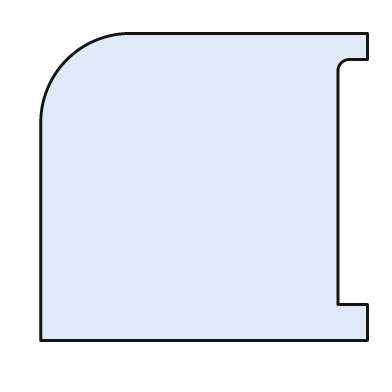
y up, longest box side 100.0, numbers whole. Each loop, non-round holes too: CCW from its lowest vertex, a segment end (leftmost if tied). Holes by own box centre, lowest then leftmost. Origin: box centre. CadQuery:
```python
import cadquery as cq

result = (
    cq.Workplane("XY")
    .moveTo(-50.0, -47.0)
    .lineTo(50.0, -47.0)
    .lineTo(50.0, -36.0)
    .lineTo(41.0, -36.0)
    .lineTo(41.0, 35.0)
    .threePointArc((42.0, 38.0), (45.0, 39.0))
    .lineTo(50.0, 39.0)
    .lineTo(50.0, 47.0)
    .lineTo(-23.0, 47.0)
    .threePointArc((-42.0, 39.0), (-50.0, 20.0))
    .close()
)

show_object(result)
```